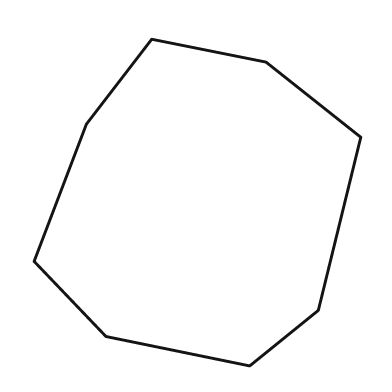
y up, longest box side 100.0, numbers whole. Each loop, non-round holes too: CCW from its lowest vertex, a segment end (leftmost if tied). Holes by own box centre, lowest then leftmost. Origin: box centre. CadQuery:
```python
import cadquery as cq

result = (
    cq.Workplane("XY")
    .moveTo(16.0, -50.0)
    .lineTo(37.0, -33.0)
    .lineTo(50.0, 20.0)
    .lineTo(21.0, 43.0)
    .lineTo(-14.0, 50.0)
    .lineTo(-34.0, 24.0)
    .lineTo(-50.0, -18.0)
    .lineTo(-28.0, -41.0)
    .close()
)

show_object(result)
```